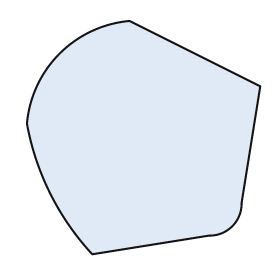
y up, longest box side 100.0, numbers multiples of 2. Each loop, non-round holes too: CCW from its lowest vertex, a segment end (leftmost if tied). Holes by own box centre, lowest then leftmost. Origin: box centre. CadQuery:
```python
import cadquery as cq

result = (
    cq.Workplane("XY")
    .moveTo(-22.0, -50.0)
    .lineTo(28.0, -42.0)
    .threePointArc((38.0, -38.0), (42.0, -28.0))
    .lineTo(50.0, 22.0)
    .lineTo(-6.0, 50.0)
    .threePointArc((-36.0, 36.0), (-50.0, 6.0))
    .threePointArc((-40.0, -24.0), (-22.0, -50.0))
    .close()
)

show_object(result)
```